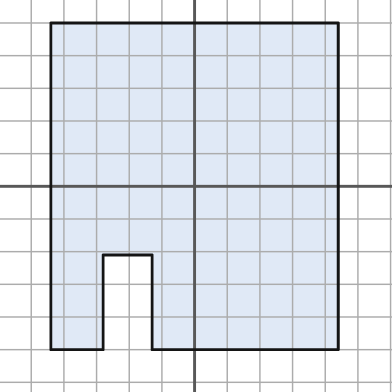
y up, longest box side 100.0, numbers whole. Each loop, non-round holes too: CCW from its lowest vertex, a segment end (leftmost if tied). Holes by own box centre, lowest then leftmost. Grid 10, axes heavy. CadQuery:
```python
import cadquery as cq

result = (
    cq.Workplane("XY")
    .moveTo(-44.0, -50.0)
    .lineTo(-28.0, -50.0)
    .lineTo(-28.0, -21.0)
    .lineTo(-13.0, -21.0)
    .lineTo(-13.0, -50.0)
    .lineTo(44.0, -50.0)
    .lineTo(44.0, 50.0)
    .lineTo(-44.0, 50.0)
    .close()
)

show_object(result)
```